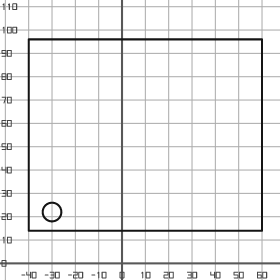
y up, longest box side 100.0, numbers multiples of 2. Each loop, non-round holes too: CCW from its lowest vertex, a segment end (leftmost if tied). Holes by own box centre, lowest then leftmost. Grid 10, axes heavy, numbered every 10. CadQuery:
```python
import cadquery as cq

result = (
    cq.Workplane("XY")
    .moveTo(-40.0, 14.0)
    .lineTo(60.0, 14.0)
    .lineTo(60.0, 96.0)
    .lineTo(-40.0, 96.0)
    .close()
    .moveTo(-30.0, 22.0)
    .circle(4.0)
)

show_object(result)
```